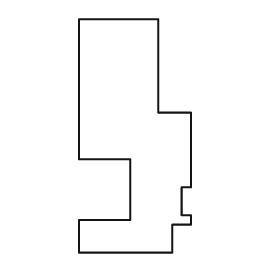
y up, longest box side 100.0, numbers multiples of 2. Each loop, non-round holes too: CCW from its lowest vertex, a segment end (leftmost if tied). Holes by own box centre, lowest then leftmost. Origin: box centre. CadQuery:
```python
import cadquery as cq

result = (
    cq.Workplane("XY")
    .moveTo(-24.0, -50.0)
    .lineTo(16.0, -50.0)
    .lineTo(16.0, -38.0)
    .lineTo(24.0, -38.0)
    .lineTo(24.0, -34.0)
    .lineTo(20.0, -34.0)
    .lineTo(20.0, -22.0)
    .lineTo(24.0, -22.0)
    .lineTo(24.0, 10.0)
    .lineTo(10.0, 10.0)
    .lineTo(10.0, 50.0)
    .lineTo(-24.0, 50.0)
    .lineTo(-24.0, -10.0)
    .lineTo(-2.0, -10.0)
    .lineTo(-2.0, -36.0)
    .lineTo(-24.0, -36.0)
    .close()
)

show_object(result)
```